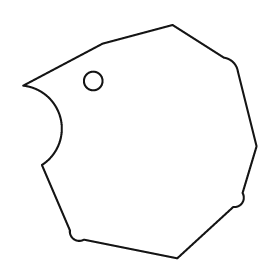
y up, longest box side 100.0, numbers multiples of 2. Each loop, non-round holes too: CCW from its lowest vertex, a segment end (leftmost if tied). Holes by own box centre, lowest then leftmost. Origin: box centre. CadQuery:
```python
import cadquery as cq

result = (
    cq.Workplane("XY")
    .moveTo(16.0, -50.0)
    .lineTo(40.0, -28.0)
    .threePointArc((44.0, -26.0), (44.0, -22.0))
    .lineTo(50.0, -2.0)
    .lineTo(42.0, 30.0)
    .threePointArc((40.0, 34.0), (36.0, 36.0))
    .lineTo(14.0, 50.0)
    .lineTo(-16.0, 42.0)
    .lineTo(-50.0, 24.0)
    .threePointArc((-34.0, 10.0), (-42.0, -10.0))
    .lineTo(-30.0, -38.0)
    .threePointArc((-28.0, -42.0), (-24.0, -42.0))
    .close()
    .moveTo(-20.0, 26.0)
    .circle(4.0)
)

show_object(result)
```